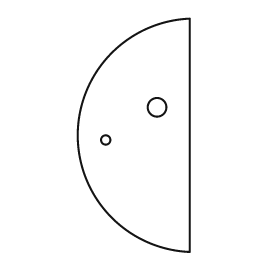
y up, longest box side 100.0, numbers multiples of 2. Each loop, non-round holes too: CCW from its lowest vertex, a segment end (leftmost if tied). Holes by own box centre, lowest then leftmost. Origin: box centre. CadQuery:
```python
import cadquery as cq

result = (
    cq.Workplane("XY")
    .moveTo(24.0, -50.0)
    .lineTo(24.0, 50.0)
    .threePointArc((-24.0, 0.0), (24.0, -50.0))
    .close()
    .moveTo(-12.0, -2.0)
    .circle(2.0)
    .moveTo(10.0, 12.0)
    .circle(4.0)
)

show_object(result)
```